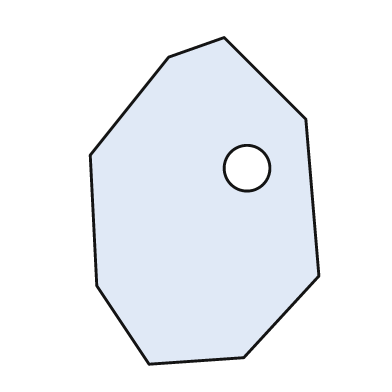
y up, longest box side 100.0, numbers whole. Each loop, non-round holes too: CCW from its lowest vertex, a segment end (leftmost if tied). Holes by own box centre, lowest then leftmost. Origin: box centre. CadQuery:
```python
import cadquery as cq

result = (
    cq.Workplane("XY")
    .moveTo(-17.0, -50.0)
    .lineTo(12.0, -48.0)
    .lineTo(35.0, -23.0)
    .lineTo(31.0, 25.0)
    .lineTo(6.0, 50.0)
    .lineTo(-11.0, 44.0)
    .lineTo(-35.0, 14.0)
    .lineTo(-33.0, -26.0)
    .close()
    .moveTo(13.0, 10.0)
    .circle(7.0)
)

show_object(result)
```